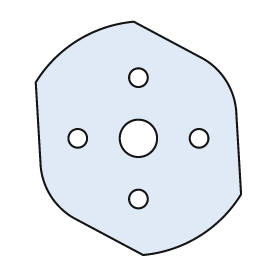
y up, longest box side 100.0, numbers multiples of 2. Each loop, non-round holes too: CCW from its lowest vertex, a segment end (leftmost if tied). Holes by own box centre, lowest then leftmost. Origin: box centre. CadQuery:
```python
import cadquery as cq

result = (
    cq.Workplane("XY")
    .moveTo(2.0, -50.0)
    .threePointArc((26.0, -42.0), (44.0, -24.0))
    .lineTo(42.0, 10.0)
    .threePointArc((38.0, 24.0), (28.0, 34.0))
    .lineTo(-2.0, 50.0)
    .threePointArc((-26.0, 42.0), (-44.0, 24.0))
    .lineTo(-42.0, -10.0)
    .threePointArc((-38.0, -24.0), (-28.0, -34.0))
    .close()
    .moveTo(0.0, -26.0)
    .circle(4.0)
    .moveTo(-26.0, 0.0)
    .circle(4.0)
    .moveTo(0.0, 0.0)
    .circle(8.0)
    .moveTo(26.0, 0.0)
    .circle(4.0)
    .moveTo(0.0, 26.0)
    .circle(4.0)
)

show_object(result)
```